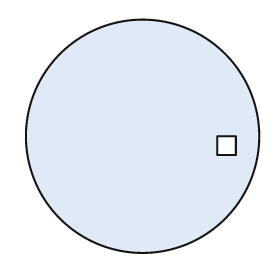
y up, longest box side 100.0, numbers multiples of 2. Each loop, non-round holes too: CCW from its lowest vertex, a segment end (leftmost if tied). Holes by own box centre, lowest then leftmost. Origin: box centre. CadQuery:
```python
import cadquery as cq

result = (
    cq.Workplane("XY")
    .moveTo(0.0, 0.0)
    .circle(50.0)
    .moveTo(32.0, -8.0)
    .lineTo(40.0, -8.0)
    .lineTo(40.0, 0.0)
    .lineTo(32.0, 0.0)
    .close()
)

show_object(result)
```